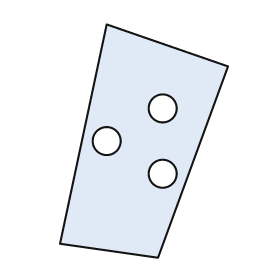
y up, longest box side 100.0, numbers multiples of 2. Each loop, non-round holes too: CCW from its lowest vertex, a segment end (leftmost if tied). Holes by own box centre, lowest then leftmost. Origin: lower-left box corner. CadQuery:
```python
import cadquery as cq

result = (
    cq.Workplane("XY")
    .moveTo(42.0, 0.0)
    .lineTo(72.0, 82.0)
    .lineTo(20.0, 100.0)
    .lineTo(0.0, 6.0)
    .close()
    .moveTo(44.0, 36.0)
    .circle(6.0)
    .moveTo(20.0, 50.0)
    .circle(6.0)
    .moveTo(44.0, 64.0)
    .circle(6.0)
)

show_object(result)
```